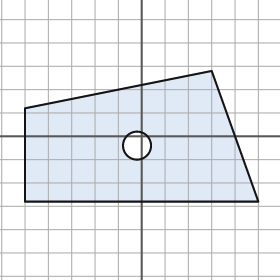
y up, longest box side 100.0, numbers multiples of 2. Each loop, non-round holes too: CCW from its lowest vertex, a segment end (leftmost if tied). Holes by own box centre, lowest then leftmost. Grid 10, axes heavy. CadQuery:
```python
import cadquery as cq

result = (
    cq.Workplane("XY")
    .moveTo(-50.0, -28.0)
    .lineTo(50.0, -28.0)
    .lineTo(30.0, 28.0)
    .lineTo(-50.0, 12.0)
    .close()
    .moveTo(-2.0, -4.0)
    .circle(6.0)
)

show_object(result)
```